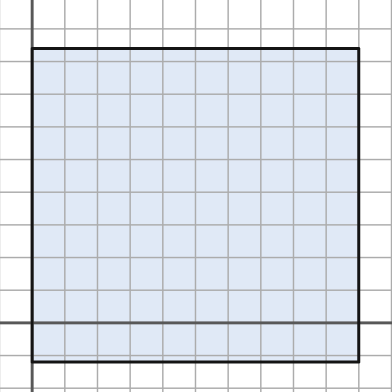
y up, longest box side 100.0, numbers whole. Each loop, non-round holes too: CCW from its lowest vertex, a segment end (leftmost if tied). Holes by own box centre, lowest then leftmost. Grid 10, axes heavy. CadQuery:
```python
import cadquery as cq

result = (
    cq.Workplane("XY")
    .moveTo(0.0, -12.0)
    .lineTo(100.0, -12.0)
    .lineTo(100.0, 84.0)
    .lineTo(0.0, 84.0)
    .close()
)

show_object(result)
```